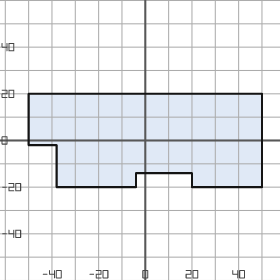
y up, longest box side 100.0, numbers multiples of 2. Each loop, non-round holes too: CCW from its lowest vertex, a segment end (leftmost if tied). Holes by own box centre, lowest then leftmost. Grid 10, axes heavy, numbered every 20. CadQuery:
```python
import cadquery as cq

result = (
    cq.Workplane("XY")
    .moveTo(-38.0, -20.0)
    .lineTo(-4.0, -20.0)
    .lineTo(-4.0, -14.0)
    .lineTo(20.0, -14.0)
    .lineTo(20.0, -20.0)
    .lineTo(50.0, -20.0)
    .lineTo(50.0, 20.0)
    .lineTo(-50.0, 20.0)
    .lineTo(-50.0, -2.0)
    .lineTo(-38.0, -2.0)
    .close()
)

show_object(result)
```